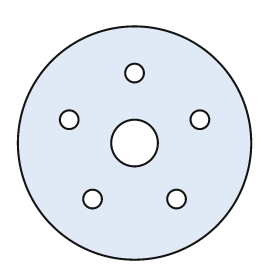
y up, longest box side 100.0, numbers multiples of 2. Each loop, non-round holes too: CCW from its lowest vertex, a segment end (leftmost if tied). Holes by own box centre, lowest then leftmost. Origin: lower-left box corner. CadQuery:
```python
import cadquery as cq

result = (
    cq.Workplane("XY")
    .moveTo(50.0, 50.0)
    .circle(50.0)
    .moveTo(32.0, 26.0)
    .circle(4.0)
    .moveTo(68.0, 26.0)
    .circle(4.0)
    .moveTo(50.0, 50.0)
    .circle(10.0)
    .moveTo(22.0, 60.0)
    .circle(4.0)
    .moveTo(78.0, 60.0)
    .circle(4.0)
    .moveTo(50.0, 80.0)
    .circle(4.0)
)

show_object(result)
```